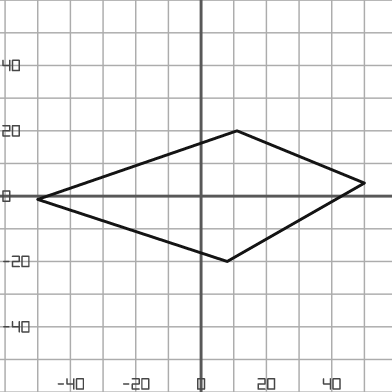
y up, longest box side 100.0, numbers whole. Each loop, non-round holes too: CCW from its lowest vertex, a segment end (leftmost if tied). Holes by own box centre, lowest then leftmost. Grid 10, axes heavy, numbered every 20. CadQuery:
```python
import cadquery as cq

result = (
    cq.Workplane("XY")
    .moveTo(8.0, -20.0)
    .lineTo(50.0, 4.0)
    .lineTo(11.0, 20.0)
    .lineTo(-50.0, -1.0)
    .close()
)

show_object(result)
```